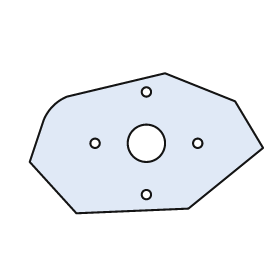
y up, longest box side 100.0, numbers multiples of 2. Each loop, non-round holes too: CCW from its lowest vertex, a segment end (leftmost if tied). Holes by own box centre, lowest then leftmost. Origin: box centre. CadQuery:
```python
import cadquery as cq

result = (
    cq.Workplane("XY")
    .moveTo(-30.0, -30.0)
    .lineTo(18.0, -28.0)
    .lineTo(50.0, -2.0)
    .lineTo(38.0, 18.0)
    .lineTo(8.0, 30.0)
    .lineTo(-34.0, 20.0)
    .threePointArc((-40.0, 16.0), (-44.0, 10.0))
    .lineTo(-50.0, -8.0)
    .close()
    .moveTo(0.0, -22.0)
    .circle(2.0)
    .moveTo(-22.0, 0.0)
    .circle(2.0)
    .moveTo(0.0, 0.0)
    .circle(8.0)
    .moveTo(22.0, 0.0)
    .circle(2.0)
    .moveTo(0.0, 22.0)
    .circle(2.0)
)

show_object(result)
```